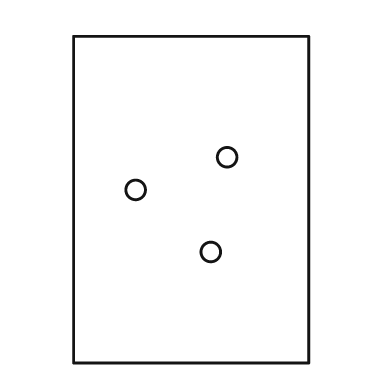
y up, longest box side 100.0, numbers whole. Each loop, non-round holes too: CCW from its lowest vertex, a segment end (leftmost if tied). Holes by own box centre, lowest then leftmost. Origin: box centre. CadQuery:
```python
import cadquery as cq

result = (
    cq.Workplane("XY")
    .moveTo(-36.0, -50.0)
    .lineTo(36.0, -50.0)
    .lineTo(36.0, 50.0)
    .lineTo(-36.0, 50.0)
    .close()
    .moveTo(6.0, -16.0)
    .circle(3.0)
    .moveTo(-17.0, 3.0)
    .circle(3.0)
    .moveTo(11.0, 13.0)
    .circle(3.0)
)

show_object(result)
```